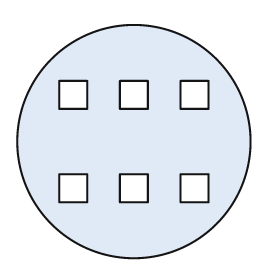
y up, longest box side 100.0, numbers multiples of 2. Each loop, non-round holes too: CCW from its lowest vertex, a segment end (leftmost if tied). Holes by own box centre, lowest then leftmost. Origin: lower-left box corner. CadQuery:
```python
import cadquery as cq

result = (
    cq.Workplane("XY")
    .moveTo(50.0, 50.0)
    .circle(50.0)
    .moveTo(18.0, 24.0)
    .lineTo(30.0, 24.0)
    .lineTo(30.0, 36.0)
    .lineTo(18.0, 36.0)
    .close()
    .moveTo(44.0, 24.0)
    .lineTo(56.0, 24.0)
    .lineTo(56.0, 36.0)
    .lineTo(44.0, 36.0)
    .close()
    .moveTo(70.0, 24.0)
    .lineTo(82.0, 24.0)
    .lineTo(82.0, 36.0)
    .lineTo(70.0, 36.0)
    .close()
    .moveTo(18.0, 64.0)
    .lineTo(30.0, 64.0)
    .lineTo(30.0, 76.0)
    .lineTo(18.0, 76.0)
    .close()
    .moveTo(44.0, 64.0)
    .lineTo(56.0, 64.0)
    .lineTo(56.0, 76.0)
    .lineTo(44.0, 76.0)
    .close()
    .moveTo(70.0, 64.0)
    .lineTo(82.0, 64.0)
    .lineTo(82.0, 76.0)
    .lineTo(70.0, 76.0)
    .close()
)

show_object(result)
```